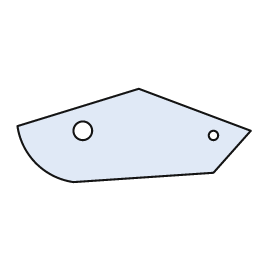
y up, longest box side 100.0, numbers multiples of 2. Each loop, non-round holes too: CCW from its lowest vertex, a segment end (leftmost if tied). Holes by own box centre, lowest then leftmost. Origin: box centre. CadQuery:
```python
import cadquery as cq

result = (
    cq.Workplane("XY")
    .moveTo(-26.0, -20.0)
    .lineTo(34.0, -16.0)
    .lineTo(50.0, 2.0)
    .lineTo(2.0, 20.0)
    .lineTo(-50.0, 4.0)
    .threePointArc((-42.0, -12.0), (-26.0, -20.0))
    .close()
    .moveTo(34.0, 0.0)
    .circle(2.0)
    .moveTo(-22.0, 2.0)
    .circle(4.0)
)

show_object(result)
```